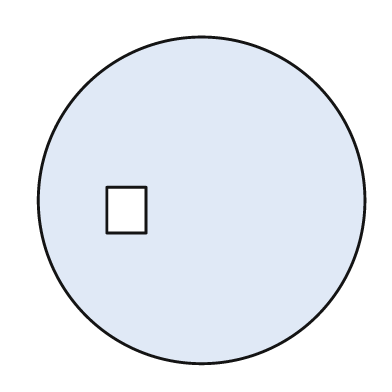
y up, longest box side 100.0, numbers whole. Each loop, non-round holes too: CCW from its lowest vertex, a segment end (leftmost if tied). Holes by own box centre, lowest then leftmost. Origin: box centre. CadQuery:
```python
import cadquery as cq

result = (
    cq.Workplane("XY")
    .moveTo(0.0, 0.0)
    .circle(50.0)
    .moveTo(-29.0, -10.0)
    .lineTo(-17.0, -10.0)
    .lineTo(-17.0, 4.0)
    .lineTo(-29.0, 4.0)
    .close()
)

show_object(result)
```